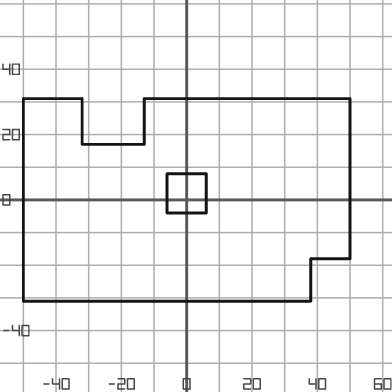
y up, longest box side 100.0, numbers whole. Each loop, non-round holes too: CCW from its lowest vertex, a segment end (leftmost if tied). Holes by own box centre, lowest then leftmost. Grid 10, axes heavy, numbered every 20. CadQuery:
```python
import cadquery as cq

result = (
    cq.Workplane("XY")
    .moveTo(-50.0, -31.0)
    .lineTo(38.0, -31.0)
    .lineTo(38.0, -18.0)
    .lineTo(50.0, -18.0)
    .lineTo(50.0, 31.0)
    .lineTo(-13.0, 31.0)
    .lineTo(-13.0, 17.0)
    .lineTo(-32.0, 17.0)
    .lineTo(-32.0, 31.0)
    .lineTo(-50.0, 31.0)
    .close()
    .moveTo(-6.0, -4.0)
    .lineTo(6.0, -4.0)
    .lineTo(6.0, 8.0)
    .lineTo(-6.0, 8.0)
    .close()
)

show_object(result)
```